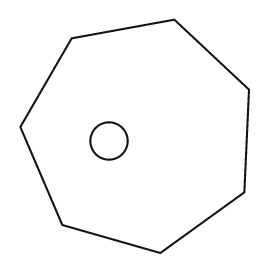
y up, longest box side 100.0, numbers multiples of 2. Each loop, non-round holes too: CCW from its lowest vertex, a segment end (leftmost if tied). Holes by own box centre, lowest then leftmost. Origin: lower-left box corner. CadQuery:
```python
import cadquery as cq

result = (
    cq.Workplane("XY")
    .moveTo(60.0, 0.0)
    .lineTo(96.0, 26.0)
    .lineTo(98.0, 70.0)
    .lineTo(66.0, 100.0)
    .lineTo(22.0, 92.0)
    .lineTo(0.0, 54.0)
    .lineTo(18.0, 12.0)
    .close()
    .moveTo(38.0, 48.0)
    .circle(8.0)
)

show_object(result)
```